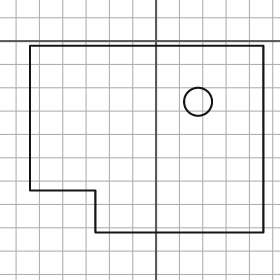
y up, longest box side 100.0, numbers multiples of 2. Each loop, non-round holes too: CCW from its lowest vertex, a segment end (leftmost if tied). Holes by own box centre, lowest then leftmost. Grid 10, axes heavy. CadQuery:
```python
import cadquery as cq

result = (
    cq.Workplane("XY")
    .moveTo(-26.0, -82.0)
    .lineTo(46.0, -82.0)
    .lineTo(46.0, -2.0)
    .lineTo(-54.0, -2.0)
    .lineTo(-54.0, -64.0)
    .lineTo(-26.0, -64.0)
    .close()
    .moveTo(18.0, -26.0)
    .circle(6.0)
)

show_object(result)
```